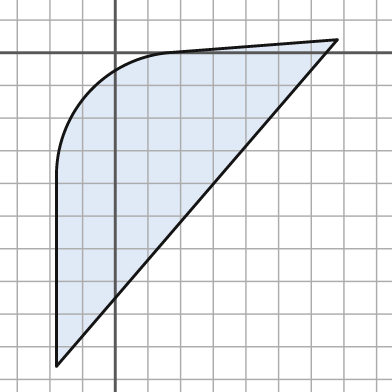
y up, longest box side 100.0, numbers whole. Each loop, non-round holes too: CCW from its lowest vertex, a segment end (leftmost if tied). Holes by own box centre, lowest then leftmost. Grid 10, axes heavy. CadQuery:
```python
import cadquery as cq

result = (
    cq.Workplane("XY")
    .moveTo(-18.0, -96.0)
    .lineTo(68.0, 4.0)
    .lineTo(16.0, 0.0)
    .threePointArc((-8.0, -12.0), (-18.0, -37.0))
    .close()
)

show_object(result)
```